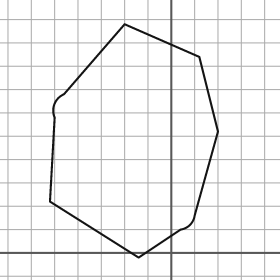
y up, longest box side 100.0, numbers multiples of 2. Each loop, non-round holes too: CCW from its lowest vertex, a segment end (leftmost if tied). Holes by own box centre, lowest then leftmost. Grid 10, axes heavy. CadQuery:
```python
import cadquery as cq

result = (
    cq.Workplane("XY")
    .moveTo(-14.0, -2.0)
    .lineTo(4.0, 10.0)
    .threePointArc((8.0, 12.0), (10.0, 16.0))
    .lineTo(20.0, 52.0)
    .lineTo(12.0, 84.0)
    .lineTo(-20.0, 98.0)
    .lineTo(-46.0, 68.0)
    .threePointArc((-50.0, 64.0), (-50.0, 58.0))
    .lineTo(-52.0, 22.0)
    .close()
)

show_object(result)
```